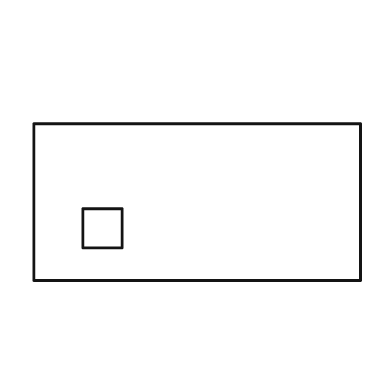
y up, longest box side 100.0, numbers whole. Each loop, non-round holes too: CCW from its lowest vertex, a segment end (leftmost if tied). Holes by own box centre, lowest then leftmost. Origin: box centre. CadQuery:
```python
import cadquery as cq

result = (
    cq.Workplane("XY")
    .moveTo(-50.0, -24.0)
    .lineTo(50.0, -24.0)
    .lineTo(50.0, 24.0)
    .lineTo(-50.0, 24.0)
    .close()
    .moveTo(-35.0, -14.0)
    .lineTo(-23.0, -14.0)
    .lineTo(-23.0, -2.0)
    .lineTo(-35.0, -2.0)
    .close()
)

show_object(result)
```